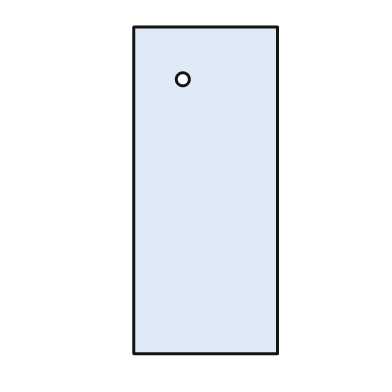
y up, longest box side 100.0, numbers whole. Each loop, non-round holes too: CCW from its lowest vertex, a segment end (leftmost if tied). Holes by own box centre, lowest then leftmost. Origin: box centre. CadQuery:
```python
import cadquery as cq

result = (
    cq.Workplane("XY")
    .moveTo(-22.0, -50.0)
    .lineTo(22.0, -50.0)
    .lineTo(22.0, 50.0)
    .lineTo(-22.0, 50.0)
    .close()
    .moveTo(-7.0, 34.0)
    .circle(2.0)
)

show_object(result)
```